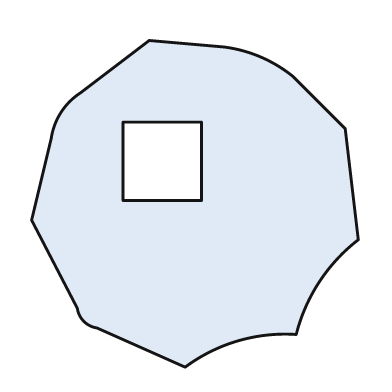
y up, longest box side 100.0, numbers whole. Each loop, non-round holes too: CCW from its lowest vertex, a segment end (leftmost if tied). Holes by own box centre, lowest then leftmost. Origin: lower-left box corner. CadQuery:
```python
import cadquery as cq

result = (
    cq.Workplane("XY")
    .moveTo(47.0, 0.0)
    .threePointArc((63.0, 8.0), (81.0, 10.0))
    .threePointArc((88.0, 26.0), (100.0, 39.0))
    .lineTo(96.0, 73.0)
    .lineTo(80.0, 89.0)
    .threePointArc((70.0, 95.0), (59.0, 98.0))
    .lineTo(36.0, 100.0)
    .lineTo(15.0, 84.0)
    .threePointArc((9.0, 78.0), (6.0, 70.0))
    .lineTo(0.0, 45.0)
    .lineTo(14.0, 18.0)
    .threePointArc((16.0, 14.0), (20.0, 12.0))
    .close()
    .moveTo(28.0, 51.0)
    .lineTo(52.0, 51.0)
    .lineTo(52.0, 75.0)
    .lineTo(28.0, 75.0)
    .close()
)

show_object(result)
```